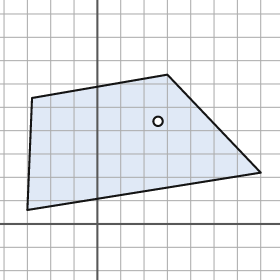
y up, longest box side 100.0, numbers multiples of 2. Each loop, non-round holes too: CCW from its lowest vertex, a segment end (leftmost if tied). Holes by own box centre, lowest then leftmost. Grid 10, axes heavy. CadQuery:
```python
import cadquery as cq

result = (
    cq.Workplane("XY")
    .moveTo(-30.0, 6.0)
    .lineTo(70.0, 22.0)
    .lineTo(30.0, 64.0)
    .lineTo(-28.0, 54.0)
    .close()
    .moveTo(26.0, 44.0)
    .circle(2.0)
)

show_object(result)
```